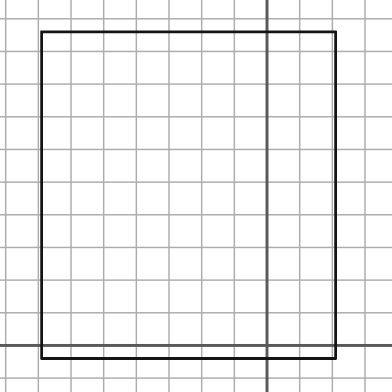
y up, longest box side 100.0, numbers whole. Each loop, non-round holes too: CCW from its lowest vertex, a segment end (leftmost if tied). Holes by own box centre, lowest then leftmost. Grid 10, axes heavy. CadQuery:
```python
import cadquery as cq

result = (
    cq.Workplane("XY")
    .moveTo(-69.0, -4.0)
    .lineTo(21.0, -4.0)
    .lineTo(21.0, 96.0)
    .lineTo(-69.0, 96.0)
    .close()
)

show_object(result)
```